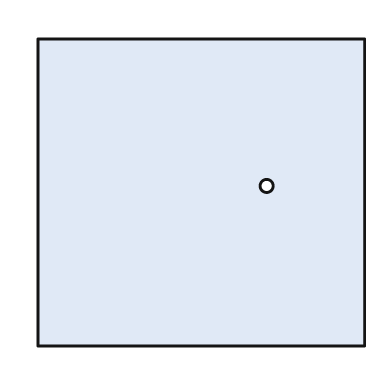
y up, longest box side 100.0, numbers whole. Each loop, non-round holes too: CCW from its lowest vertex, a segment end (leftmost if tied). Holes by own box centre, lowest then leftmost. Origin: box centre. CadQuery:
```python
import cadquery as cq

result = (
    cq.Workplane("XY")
    .moveTo(-50.0, -47.0)
    .lineTo(50.0, -47.0)
    .lineTo(50.0, 47.0)
    .lineTo(-50.0, 47.0)
    .close()
    .moveTo(20.0, 2.0)
    .circle(2.0)
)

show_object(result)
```